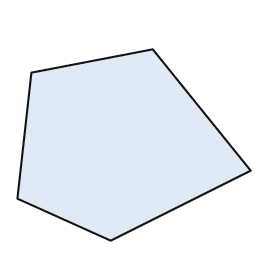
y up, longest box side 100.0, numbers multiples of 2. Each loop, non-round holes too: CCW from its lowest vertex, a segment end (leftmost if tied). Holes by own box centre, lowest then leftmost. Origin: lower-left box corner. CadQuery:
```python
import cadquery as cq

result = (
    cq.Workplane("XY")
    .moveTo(40.0, 0.0)
    .lineTo(100.0, 30.0)
    .lineTo(58.0, 82.0)
    .lineTo(6.0, 72.0)
    .lineTo(0.0, 18.0)
    .close()
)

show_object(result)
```